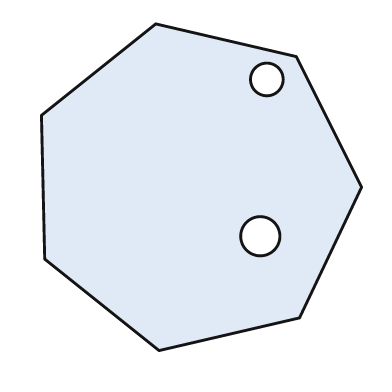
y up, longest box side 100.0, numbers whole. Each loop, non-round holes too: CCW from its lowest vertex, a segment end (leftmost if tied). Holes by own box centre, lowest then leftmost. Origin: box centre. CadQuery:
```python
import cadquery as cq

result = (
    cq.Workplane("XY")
    .moveTo(-13.0, -50.0)
    .lineTo(30.0, -40.0)
    .lineTo(49.0, 0.0)
    .lineTo(29.0, 40.0)
    .lineTo(-14.0, 50.0)
    .lineTo(-49.0, 22.0)
    .lineTo(-48.0, -22.0)
    .close()
    .moveTo(18.0, -15.0)
    .circle(6.0)
    .moveTo(20.0, 33.0)
    .circle(5.0)
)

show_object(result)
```